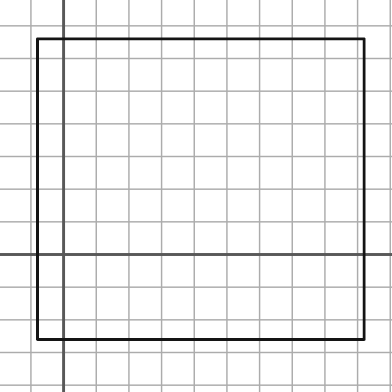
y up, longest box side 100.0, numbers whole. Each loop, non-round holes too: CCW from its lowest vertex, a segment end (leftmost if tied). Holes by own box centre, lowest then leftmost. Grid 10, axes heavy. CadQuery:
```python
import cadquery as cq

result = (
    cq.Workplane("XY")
    .moveTo(-8.0, -26.0)
    .lineTo(92.0, -26.0)
    .lineTo(92.0, 66.0)
    .lineTo(-8.0, 66.0)
    .close()
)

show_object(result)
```